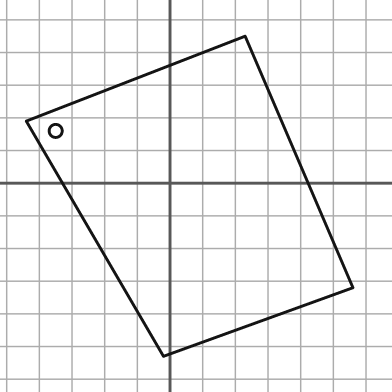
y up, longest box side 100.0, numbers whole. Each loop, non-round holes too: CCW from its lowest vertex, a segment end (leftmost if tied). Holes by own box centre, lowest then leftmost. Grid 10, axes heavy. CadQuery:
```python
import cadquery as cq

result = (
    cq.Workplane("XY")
    .moveTo(-2.0, -53.0)
    .lineTo(56.0, -32.0)
    .lineTo(23.0, 45.0)
    .lineTo(-44.0, 19.0)
    .close()
    .moveTo(-35.0, 16.0)
    .circle(2.0)
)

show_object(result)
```